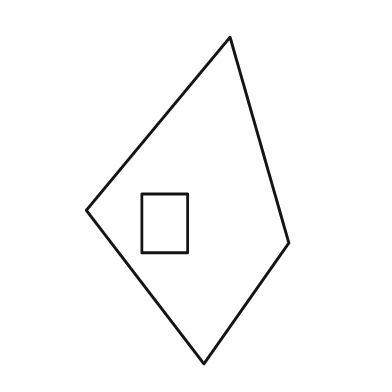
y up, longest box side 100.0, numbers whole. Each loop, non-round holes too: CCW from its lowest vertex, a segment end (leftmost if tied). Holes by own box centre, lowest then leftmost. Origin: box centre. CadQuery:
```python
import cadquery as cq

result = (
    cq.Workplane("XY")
    .moveTo(5.0, -50.0)
    .lineTo(31.0, -13.0)
    .lineTo(13.0, 50.0)
    .lineTo(-31.0, -3.0)
    .close()
    .moveTo(-14.0, -16.0)
    .lineTo(0.0, -16.0)
    .lineTo(0.0, 2.0)
    .lineTo(-14.0, 2.0)
    .close()
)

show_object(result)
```